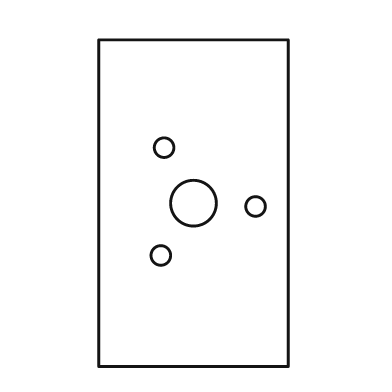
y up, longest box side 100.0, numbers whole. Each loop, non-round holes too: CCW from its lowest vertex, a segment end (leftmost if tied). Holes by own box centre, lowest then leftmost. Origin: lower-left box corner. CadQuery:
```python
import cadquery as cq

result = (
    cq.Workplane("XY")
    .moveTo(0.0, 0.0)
    .lineTo(58.0, 0.0)
    .lineTo(58.0, 100.0)
    .lineTo(0.0, 100.0)
    .close()
    .moveTo(19.0, 34.0)
    .circle(3.0)
    .moveTo(48.0, 49.0)
    .circle(3.0)
    .moveTo(29.0, 50.0)
    .circle(7.0)
    .moveTo(20.0, 67.0)
    .circle(3.0)
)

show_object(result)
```